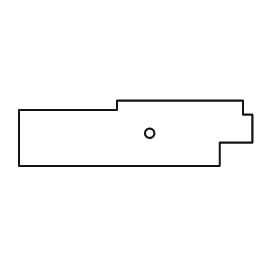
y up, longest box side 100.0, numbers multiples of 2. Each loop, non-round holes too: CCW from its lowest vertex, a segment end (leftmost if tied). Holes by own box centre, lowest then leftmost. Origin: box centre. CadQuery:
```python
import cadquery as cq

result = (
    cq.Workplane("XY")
    .moveTo(-50.0, -14.0)
    .lineTo(36.0, -14.0)
    .lineTo(36.0, -4.0)
    .lineTo(50.0, -4.0)
    .lineTo(50.0, 8.0)
    .lineTo(46.0, 8.0)
    .lineTo(46.0, 14.0)
    .lineTo(-8.0, 14.0)
    .lineTo(-8.0, 10.0)
    .lineTo(-50.0, 10.0)
    .close()
    .moveTo(6.0, 0.0)
    .circle(2.0)
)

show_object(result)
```